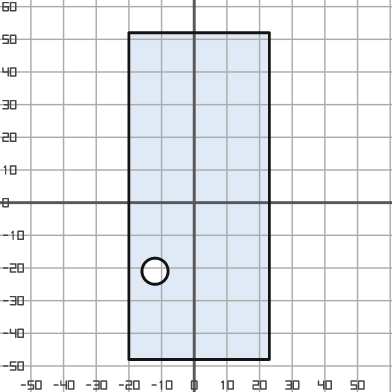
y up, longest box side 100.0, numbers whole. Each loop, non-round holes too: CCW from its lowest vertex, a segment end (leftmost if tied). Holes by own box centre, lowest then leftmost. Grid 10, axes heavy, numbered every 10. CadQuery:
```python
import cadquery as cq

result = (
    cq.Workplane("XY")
    .moveTo(-20.0, -48.0)
    .lineTo(23.0, -48.0)
    .lineTo(23.0, 52.0)
    .lineTo(-20.0, 52.0)
    .close()
    .moveTo(-12.0, -21.0)
    .circle(4.0)
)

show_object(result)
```